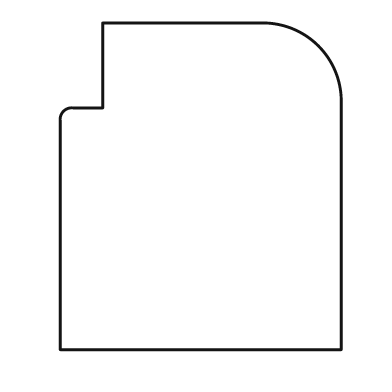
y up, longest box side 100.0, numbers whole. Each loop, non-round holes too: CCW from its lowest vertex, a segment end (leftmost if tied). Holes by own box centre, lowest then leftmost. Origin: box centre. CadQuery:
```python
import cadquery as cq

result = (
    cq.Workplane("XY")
    .moveTo(-43.0, -50.0)
    .lineTo(43.0, -50.0)
    .lineTo(43.0, 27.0)
    .threePointArc((36.0, 43.0), (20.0, 50.0))
    .lineTo(-30.0, 50.0)
    .lineTo(-30.0, 24.0)
    .lineTo(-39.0, 24.0)
    .threePointArc((-42.0, 23.0), (-43.0, 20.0))
    .close()
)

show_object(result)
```